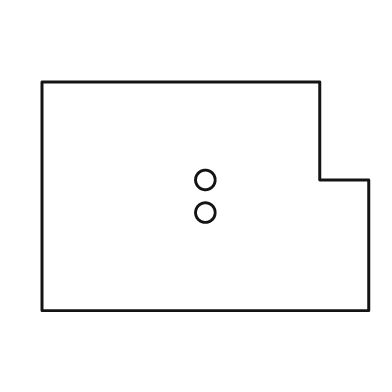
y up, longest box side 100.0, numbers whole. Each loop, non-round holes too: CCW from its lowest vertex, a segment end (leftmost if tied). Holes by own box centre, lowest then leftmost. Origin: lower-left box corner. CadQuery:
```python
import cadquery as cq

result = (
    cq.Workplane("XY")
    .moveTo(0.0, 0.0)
    .lineTo(100.0, 0.0)
    .lineTo(100.0, 40.0)
    .lineTo(85.0, 40.0)
    .lineTo(85.0, 70.0)
    .lineTo(0.0, 70.0)
    .close()
    .moveTo(50.0, 30.0)
    .circle(3.0)
    .moveTo(50.0, 40.0)
    .circle(3.0)
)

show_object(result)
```